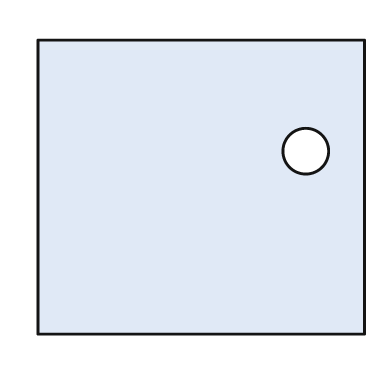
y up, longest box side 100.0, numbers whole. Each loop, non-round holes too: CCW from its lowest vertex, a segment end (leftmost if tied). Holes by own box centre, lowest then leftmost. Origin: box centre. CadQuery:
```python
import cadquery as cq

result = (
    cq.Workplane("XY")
    .moveTo(-50.0, -45.0)
    .lineTo(50.0, -45.0)
    .lineTo(50.0, 45.0)
    .lineTo(-50.0, 45.0)
    .close()
    .moveTo(32.0, 11.0)
    .circle(7.0)
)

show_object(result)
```